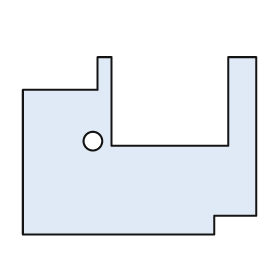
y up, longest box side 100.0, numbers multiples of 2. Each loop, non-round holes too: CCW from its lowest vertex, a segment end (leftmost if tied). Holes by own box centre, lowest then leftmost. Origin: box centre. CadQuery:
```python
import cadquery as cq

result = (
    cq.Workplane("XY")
    .moveTo(-50.0, -38.0)
    .lineTo(32.0, -38.0)
    .lineTo(32.0, -30.0)
    .lineTo(50.0, -30.0)
    .lineTo(50.0, 38.0)
    .lineTo(38.0, 38.0)
    .lineTo(38.0, 0.0)
    .lineTo(-12.0, 0.0)
    .lineTo(-12.0, 38.0)
    .lineTo(-18.0, 38.0)
    .lineTo(-18.0, 24.0)
    .lineTo(-50.0, 24.0)
    .close()
    .moveTo(-20.0, 2.0)
    .circle(4.0)
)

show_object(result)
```